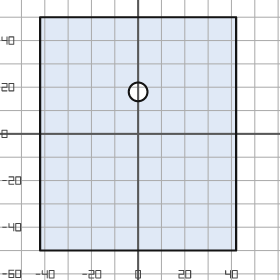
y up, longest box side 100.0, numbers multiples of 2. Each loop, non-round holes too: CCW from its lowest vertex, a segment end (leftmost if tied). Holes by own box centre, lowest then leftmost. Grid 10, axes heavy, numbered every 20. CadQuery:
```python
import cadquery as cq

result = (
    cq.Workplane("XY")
    .moveTo(-42.0, -50.0)
    .lineTo(42.0, -50.0)
    .lineTo(42.0, 50.0)
    .lineTo(-42.0, 50.0)
    .close()
    .moveTo(0.0, 18.0)
    .circle(4.0)
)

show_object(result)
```